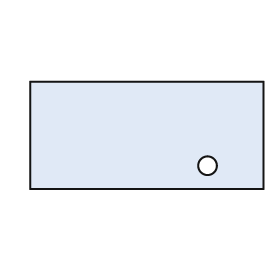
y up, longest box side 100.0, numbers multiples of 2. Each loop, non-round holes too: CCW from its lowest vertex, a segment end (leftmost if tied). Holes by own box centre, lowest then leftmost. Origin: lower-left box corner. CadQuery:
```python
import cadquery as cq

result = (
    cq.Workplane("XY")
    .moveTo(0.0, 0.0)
    .lineTo(100.0, 0.0)
    .lineTo(100.0, 46.0)
    .lineTo(0.0, 46.0)
    .close()
    .moveTo(76.0, 10.0)
    .circle(4.0)
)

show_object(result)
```